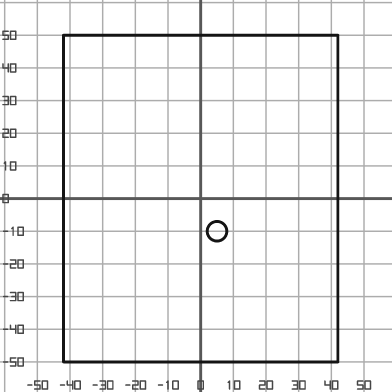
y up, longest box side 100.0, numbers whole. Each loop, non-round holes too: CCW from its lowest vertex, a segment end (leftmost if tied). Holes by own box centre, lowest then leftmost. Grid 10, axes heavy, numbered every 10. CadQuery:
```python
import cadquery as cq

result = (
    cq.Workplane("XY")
    .moveTo(-42.0, -50.0)
    .lineTo(42.0, -50.0)
    .lineTo(42.0, 50.0)
    .lineTo(-42.0, 50.0)
    .close()
    .moveTo(5.0, -10.0)
    .circle(3.0)
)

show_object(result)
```